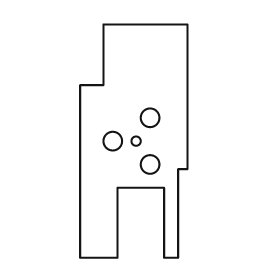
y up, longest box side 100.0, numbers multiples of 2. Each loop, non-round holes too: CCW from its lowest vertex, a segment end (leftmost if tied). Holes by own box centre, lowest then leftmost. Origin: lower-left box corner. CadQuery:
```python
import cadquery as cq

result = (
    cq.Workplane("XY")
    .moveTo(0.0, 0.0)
    .lineTo(16.0, 0.0)
    .lineTo(16.0, 30.0)
    .lineTo(36.0, 30.0)
    .lineTo(36.0, 0.0)
    .lineTo(42.0, 0.0)
    .lineTo(42.0, 38.0)
    .lineTo(46.0, 38.0)
    .lineTo(46.0, 100.0)
    .lineTo(10.0, 100.0)
    .lineTo(10.0, 74.0)
    .lineTo(0.0, 74.0)
    .close()
    .moveTo(30.0, 40.0)
    .circle(4.0)
    .moveTo(14.0, 50.0)
    .circle(4.0)
    .moveTo(24.0, 50.0)
    .circle(2.0)
    .moveTo(30.0, 60.0)
    .circle(4.0)
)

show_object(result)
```